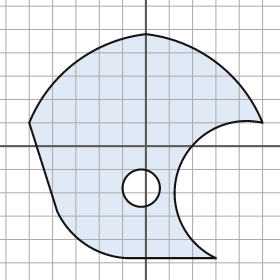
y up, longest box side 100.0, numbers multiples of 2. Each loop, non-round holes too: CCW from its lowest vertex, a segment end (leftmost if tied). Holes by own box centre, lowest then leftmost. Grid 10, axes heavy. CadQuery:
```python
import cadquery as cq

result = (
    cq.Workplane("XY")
    .moveTo(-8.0, -48.0)
    .lineTo(30.0, -48.0)
    .threePointArc((14.0, -10.0), (50.0, 10.0))
    .threePointArc((30.0, 36.0), (0.0, 48.0))
    .threePointArc((-30.0, 36.0), (-50.0, 10.0))
    .lineTo(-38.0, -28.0)
    .threePointArc((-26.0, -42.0), (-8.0, -48.0))
    .close()
    .moveTo(-2.0, -18.0)
    .circle(8.0)
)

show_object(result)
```